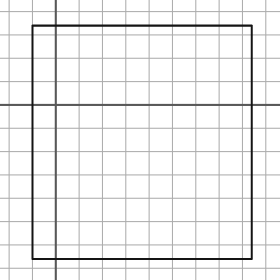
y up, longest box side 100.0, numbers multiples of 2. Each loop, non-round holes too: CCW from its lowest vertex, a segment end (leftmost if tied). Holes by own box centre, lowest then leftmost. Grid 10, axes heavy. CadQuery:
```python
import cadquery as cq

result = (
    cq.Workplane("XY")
    .moveTo(-10.0, -66.0)
    .lineTo(84.0, -66.0)
    .lineTo(84.0, 34.0)
    .lineTo(-10.0, 34.0)
    .close()
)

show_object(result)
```